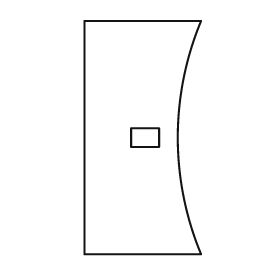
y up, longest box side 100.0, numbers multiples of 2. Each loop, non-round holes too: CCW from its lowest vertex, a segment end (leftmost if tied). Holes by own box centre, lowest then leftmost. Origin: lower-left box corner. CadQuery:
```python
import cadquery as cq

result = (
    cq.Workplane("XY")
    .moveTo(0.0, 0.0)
    .lineTo(50.0, 0.0)
    .threePointArc((40.0, 50.0), (50.0, 100.0))
    .lineTo(0.0, 100.0)
    .close()
    .moveTo(20.0, 46.0)
    .lineTo(32.0, 46.0)
    .lineTo(32.0, 54.0)
    .lineTo(20.0, 54.0)
    .close()
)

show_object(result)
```